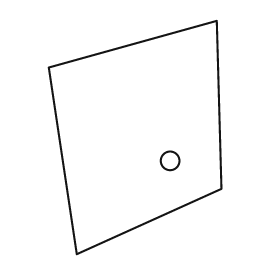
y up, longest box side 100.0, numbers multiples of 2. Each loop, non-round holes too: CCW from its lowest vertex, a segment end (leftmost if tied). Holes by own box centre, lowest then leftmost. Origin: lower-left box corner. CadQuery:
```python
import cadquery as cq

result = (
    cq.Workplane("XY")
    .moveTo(12.0, 0.0)
    .lineTo(74.0, 28.0)
    .lineTo(72.0, 100.0)
    .lineTo(0.0, 80.0)
    .close()
    .moveTo(52.0, 40.0)
    .circle(4.0)
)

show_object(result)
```